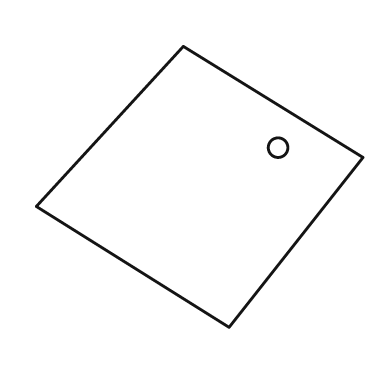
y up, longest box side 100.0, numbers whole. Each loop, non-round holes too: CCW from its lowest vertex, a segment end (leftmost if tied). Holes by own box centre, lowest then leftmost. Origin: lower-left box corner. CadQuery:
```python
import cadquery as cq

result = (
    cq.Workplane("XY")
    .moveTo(59.0, 0.0)
    .lineTo(100.0, 52.0)
    .lineTo(45.0, 86.0)
    .lineTo(0.0, 37.0)
    .close()
    .moveTo(74.0, 55.0)
    .circle(3.0)
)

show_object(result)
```